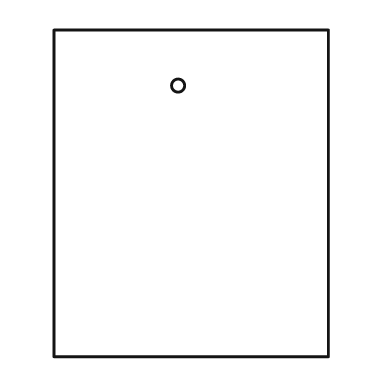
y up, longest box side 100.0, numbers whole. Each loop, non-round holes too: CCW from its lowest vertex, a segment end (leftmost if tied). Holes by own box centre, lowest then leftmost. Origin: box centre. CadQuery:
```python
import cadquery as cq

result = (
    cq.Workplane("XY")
    .moveTo(-42.0, -50.0)
    .lineTo(42.0, -50.0)
    .lineTo(42.0, 50.0)
    .lineTo(-42.0, 50.0)
    .close()
    .moveTo(-4.0, 33.0)
    .circle(2.0)
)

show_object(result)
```